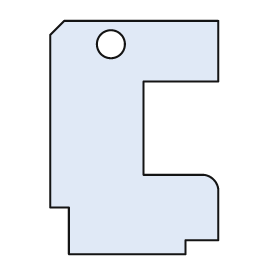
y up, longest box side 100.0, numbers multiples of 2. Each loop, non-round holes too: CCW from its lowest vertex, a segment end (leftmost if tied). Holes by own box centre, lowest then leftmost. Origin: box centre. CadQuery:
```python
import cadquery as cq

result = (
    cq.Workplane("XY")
    .moveTo(-28.0, -50.0)
    .lineTo(22.0, -50.0)
    .lineTo(22.0, -44.0)
    .lineTo(36.0, -44.0)
    .lineTo(36.0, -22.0)
    .threePointArc((34.0, -18.0), (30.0, -16.0))
    .lineTo(4.0, -16.0)
    .lineTo(4.0, 24.0)
    .lineTo(36.0, 24.0)
    .lineTo(36.0, 50.0)
    .lineTo(-30.0, 50.0)
    .lineTo(-36.0, 44.0)
    .lineTo(-36.0, -30.0)
    .lineTo(-28.0, -30.0)
    .close()
    .moveTo(-10.0, 40.0)
    .circle(6.0)
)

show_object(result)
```